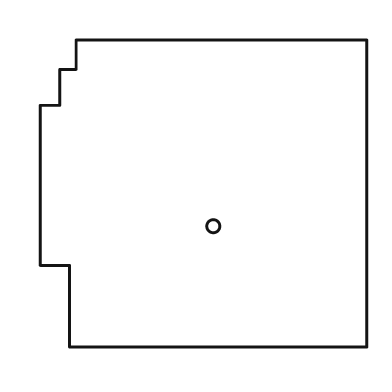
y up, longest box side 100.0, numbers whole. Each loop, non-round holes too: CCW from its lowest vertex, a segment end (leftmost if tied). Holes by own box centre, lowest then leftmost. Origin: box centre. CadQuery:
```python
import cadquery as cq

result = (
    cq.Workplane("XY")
    .moveTo(-41.0, -47.0)
    .lineTo(50.0, -47.0)
    .lineTo(50.0, 47.0)
    .lineTo(-39.0, 47.0)
    .lineTo(-39.0, 38.0)
    .lineTo(-44.0, 38.0)
    .lineTo(-44.0, 27.0)
    .lineTo(-50.0, 27.0)
    .lineTo(-50.0, -22.0)
    .lineTo(-41.0, -22.0)
    .close()
    .moveTo(3.0, -10.0)
    .circle(2.0)
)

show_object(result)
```